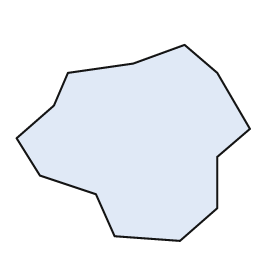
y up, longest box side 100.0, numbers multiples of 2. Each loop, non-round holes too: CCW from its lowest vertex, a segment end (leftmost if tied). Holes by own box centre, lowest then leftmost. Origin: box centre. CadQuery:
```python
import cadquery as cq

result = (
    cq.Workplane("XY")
    .moveTo(20.0, -42.0)
    .lineTo(36.0, -28.0)
    .lineTo(36.0, -6.0)
    .lineTo(50.0, 6.0)
    .lineTo(36.0, 30.0)
    .lineTo(22.0, 42.0)
    .lineTo(0.0, 34.0)
    .lineTo(-28.0, 30.0)
    .lineTo(-34.0, 16.0)
    .lineTo(-50.0, 2.0)
    .lineTo(-40.0, -14.0)
    .lineTo(-16.0, -22.0)
    .lineTo(-8.0, -40.0)
    .close()
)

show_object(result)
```